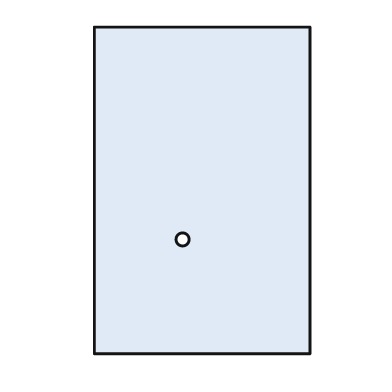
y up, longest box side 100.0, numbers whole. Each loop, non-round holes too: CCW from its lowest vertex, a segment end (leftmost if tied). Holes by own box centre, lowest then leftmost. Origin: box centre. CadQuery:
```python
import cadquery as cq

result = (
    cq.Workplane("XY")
    .moveTo(-33.0, -50.0)
    .lineTo(33.0, -50.0)
    .lineTo(33.0, 50.0)
    .lineTo(-33.0, 50.0)
    .close()
    .moveTo(-6.0, -15.0)
    .circle(2.0)
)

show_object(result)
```